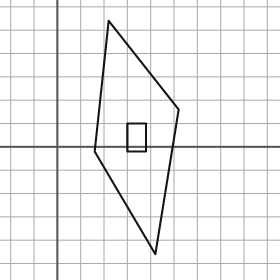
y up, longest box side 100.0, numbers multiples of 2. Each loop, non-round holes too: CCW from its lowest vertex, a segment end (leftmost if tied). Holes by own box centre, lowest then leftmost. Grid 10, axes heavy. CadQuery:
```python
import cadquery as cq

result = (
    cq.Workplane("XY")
    .moveTo(42.0, -46.0)
    .lineTo(52.0, 16.0)
    .lineTo(22.0, 54.0)
    .lineTo(16.0, -2.0)
    .close()
    .moveTo(30.0, -2.0)
    .lineTo(38.0, -2.0)
    .lineTo(38.0, 10.0)
    .lineTo(30.0, 10.0)
    .close()
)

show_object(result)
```